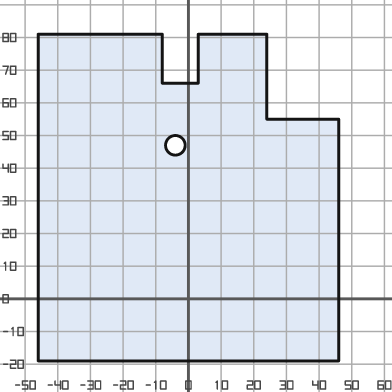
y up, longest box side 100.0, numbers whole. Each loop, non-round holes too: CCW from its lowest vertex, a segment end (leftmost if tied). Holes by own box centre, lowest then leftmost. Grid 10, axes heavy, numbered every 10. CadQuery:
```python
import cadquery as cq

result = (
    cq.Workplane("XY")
    .moveTo(-46.0, -19.0)
    .lineTo(46.0, -19.0)
    .lineTo(46.0, 55.0)
    .lineTo(24.0, 55.0)
    .lineTo(24.0, 81.0)
    .lineTo(3.0, 81.0)
    .lineTo(3.0, 66.0)
    .lineTo(-8.0, 66.0)
    .lineTo(-8.0, 81.0)
    .lineTo(-46.0, 81.0)
    .close()
    .moveTo(-4.0, 47.0)
    .circle(3.0)
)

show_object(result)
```